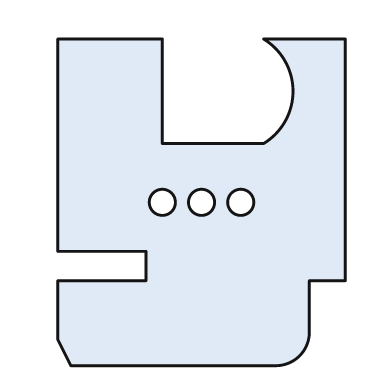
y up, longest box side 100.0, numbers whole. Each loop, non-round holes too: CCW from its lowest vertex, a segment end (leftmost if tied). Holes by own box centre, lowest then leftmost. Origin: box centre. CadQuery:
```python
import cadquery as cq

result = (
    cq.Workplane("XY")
    .moveTo(-40.0, -50.0)
    .lineTo(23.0, -50.0)
    .threePointArc((30.0, -47.0), (33.0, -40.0))
    .lineTo(33.0, -24.0)
    .lineTo(44.0, -24.0)
    .lineTo(44.0, 50.0)
    .lineTo(19.0, 50.0)
    .threePointArc((28.0, 34.0), (19.0, 18.0))
    .lineTo(-12.0, 18.0)
    .lineTo(-12.0, 50.0)
    .lineTo(-44.0, 50.0)
    .lineTo(-44.0, -15.0)
    .lineTo(-17.0, -15.0)
    .lineTo(-17.0, -24.0)
    .lineTo(-44.0, -24.0)
    .lineTo(-44.0, -42.0)
    .close()
    .moveTo(-12.0, 0.0)
    .circle(4.0)
    .moveTo(0.0, 0.0)
    .circle(4.0)
    .moveTo(12.0, 0.0)
    .circle(4.0)
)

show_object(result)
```